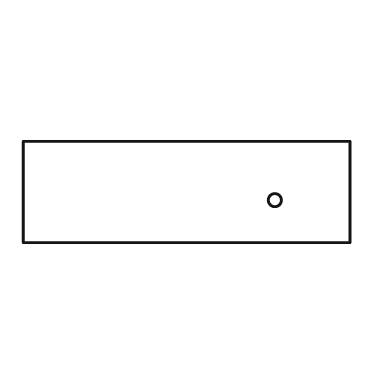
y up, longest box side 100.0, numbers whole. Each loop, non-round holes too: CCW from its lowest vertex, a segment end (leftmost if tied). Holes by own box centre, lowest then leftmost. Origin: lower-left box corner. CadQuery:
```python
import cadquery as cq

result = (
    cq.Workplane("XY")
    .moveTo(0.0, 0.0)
    .lineTo(100.0, 0.0)
    .lineTo(100.0, 31.0)
    .lineTo(0.0, 31.0)
    .close()
    .moveTo(77.0, 13.0)
    .circle(2.0)
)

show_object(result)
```